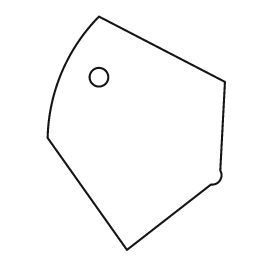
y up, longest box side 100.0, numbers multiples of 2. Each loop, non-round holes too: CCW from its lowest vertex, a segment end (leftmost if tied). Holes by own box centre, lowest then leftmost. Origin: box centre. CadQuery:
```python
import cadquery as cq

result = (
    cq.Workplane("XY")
    .moveTo(-4.0, -50.0)
    .lineTo(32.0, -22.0)
    .threePointArc((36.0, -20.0), (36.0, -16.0))
    .lineTo(38.0, 22.0)
    .lineTo(-16.0, 50.0)
    .threePointArc((-32.0, 26.0), (-38.0, -2.0))
    .close()
    .moveTo(-16.0, 24.0)
    .circle(4.0)
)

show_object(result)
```